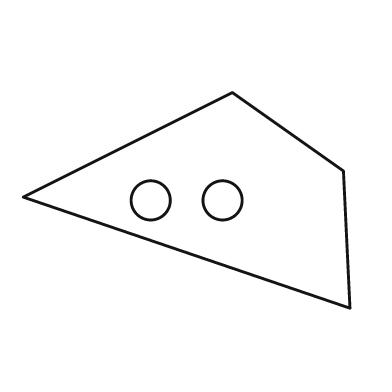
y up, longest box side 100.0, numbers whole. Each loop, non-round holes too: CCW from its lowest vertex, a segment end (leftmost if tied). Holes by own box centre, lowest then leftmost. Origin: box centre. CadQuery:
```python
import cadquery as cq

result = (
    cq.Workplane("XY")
    .moveTo(50.0, -33.0)
    .lineTo(48.0, 9.0)
    .lineTo(14.0, 33.0)
    .lineTo(-50.0, 1.0)
    .close()
    .moveTo(-11.0, 0.0)
    .circle(6.0)
    .moveTo(11.0, 0.0)
    .circle(6.0)
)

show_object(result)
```